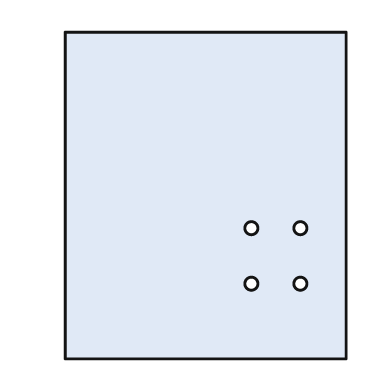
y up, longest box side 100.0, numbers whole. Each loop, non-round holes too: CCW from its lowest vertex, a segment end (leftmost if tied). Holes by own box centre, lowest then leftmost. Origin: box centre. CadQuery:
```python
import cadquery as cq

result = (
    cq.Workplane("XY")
    .moveTo(-43.0, -50.0)
    .lineTo(43.0, -50.0)
    .lineTo(43.0, 50.0)
    .lineTo(-43.0, 50.0)
    .close()
    .moveTo(14.0, -27.0)
    .circle(2.0)
    .moveTo(29.0, -27.0)
    .circle(2.0)
    .moveTo(14.0, -10.0)
    .circle(2.0)
    .moveTo(29.0, -10.0)
    .circle(2.0)
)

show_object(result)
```